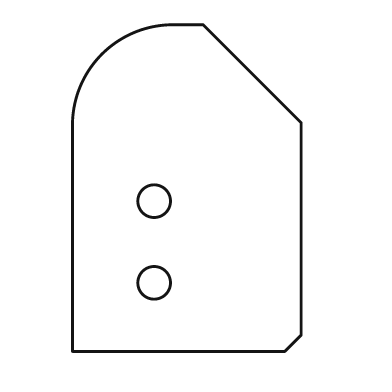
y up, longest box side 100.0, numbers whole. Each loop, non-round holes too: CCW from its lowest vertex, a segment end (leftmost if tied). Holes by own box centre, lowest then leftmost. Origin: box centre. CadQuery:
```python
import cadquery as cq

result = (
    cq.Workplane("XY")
    .moveTo(-35.0, -50.0)
    .lineTo(30.0, -50.0)
    .lineTo(35.0, -45.0)
    .lineTo(35.0, 20.0)
    .lineTo(5.0, 50.0)
    .lineTo(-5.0, 50.0)
    .threePointArc((-26.0, 41.0), (-35.0, 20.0))
    .close()
    .moveTo(-10.0, -29.0)
    .circle(5.0)
    .moveTo(-10.0, -4.0)
    .circle(5.0)
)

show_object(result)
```